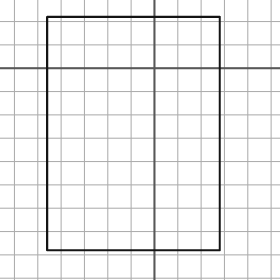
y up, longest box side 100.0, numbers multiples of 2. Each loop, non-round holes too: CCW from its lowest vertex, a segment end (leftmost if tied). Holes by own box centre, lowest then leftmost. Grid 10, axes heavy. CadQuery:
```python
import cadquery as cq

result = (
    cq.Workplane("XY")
    .moveTo(-46.0, -78.0)
    .lineTo(28.0, -78.0)
    .lineTo(28.0, 22.0)
    .lineTo(-46.0, 22.0)
    .close()
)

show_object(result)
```